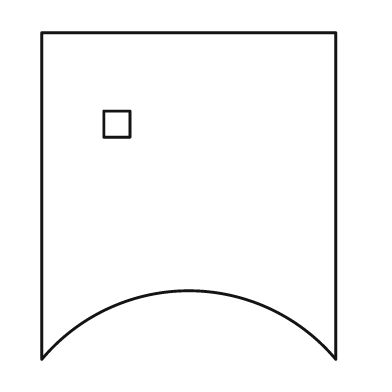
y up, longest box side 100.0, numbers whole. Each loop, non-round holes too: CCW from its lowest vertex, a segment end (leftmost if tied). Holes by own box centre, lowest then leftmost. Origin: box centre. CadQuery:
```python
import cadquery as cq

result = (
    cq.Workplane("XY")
    .moveTo(-45.0, -50.0)
    .threePointArc((0.0, -29.0), (45.0, -50.0))
    .lineTo(45.0, 50.0)
    .lineTo(-45.0, 50.0)
    .close()
    .moveTo(-26.0, 18.0)
    .lineTo(-18.0, 18.0)
    .lineTo(-18.0, 26.0)
    .lineTo(-26.0, 26.0)
    .close()
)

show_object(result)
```